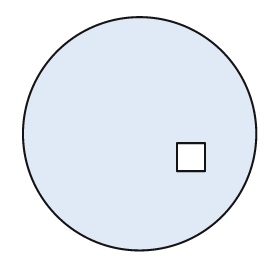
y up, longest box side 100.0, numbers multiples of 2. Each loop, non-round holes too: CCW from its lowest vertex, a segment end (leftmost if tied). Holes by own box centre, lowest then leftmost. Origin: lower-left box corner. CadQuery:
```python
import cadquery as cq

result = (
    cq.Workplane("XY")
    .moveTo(50.0, 50.0)
    .circle(50.0)
    .moveTo(66.0, 34.0)
    .lineTo(78.0, 34.0)
    .lineTo(78.0, 46.0)
    .lineTo(66.0, 46.0)
    .close()
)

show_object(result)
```